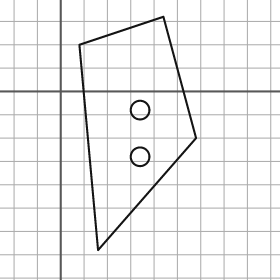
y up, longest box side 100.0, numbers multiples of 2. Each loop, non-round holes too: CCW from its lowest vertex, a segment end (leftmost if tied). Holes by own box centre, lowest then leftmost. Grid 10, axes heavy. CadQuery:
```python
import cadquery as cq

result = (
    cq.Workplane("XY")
    .moveTo(16.0, -68.0)
    .lineTo(58.0, -20.0)
    .lineTo(44.0, 32.0)
    .lineTo(8.0, 20.0)
    .close()
    .moveTo(34.0, -28.0)
    .circle(4.0)
    .moveTo(34.0, -8.0)
    .circle(4.0)
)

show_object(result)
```